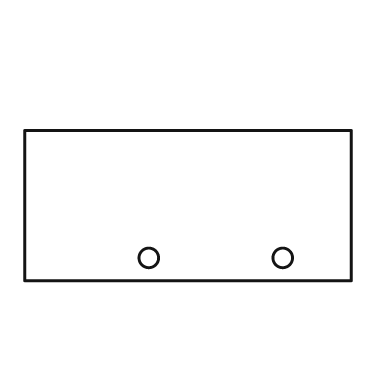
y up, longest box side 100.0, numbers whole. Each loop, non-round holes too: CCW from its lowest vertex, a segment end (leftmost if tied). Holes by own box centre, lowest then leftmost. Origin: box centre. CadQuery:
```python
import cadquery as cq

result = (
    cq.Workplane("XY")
    .moveTo(-50.0, -23.0)
    .lineTo(50.0, -23.0)
    .lineTo(50.0, 23.0)
    .lineTo(-50.0, 23.0)
    .close()
    .moveTo(-12.0, -16.0)
    .circle(3.0)
    .moveTo(29.0, -16.0)
    .circle(3.0)
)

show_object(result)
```